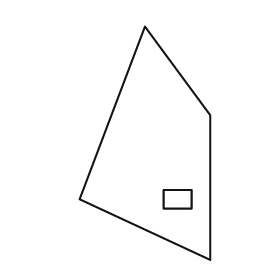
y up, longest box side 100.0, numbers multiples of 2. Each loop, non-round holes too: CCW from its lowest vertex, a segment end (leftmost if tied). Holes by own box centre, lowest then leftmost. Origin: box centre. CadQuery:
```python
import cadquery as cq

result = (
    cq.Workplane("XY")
    .moveTo(28.0, -50.0)
    .lineTo(28.0, 12.0)
    .lineTo(0.0, 50.0)
    .lineTo(-28.0, -24.0)
    .close()
    .moveTo(8.0, -28.0)
    .lineTo(20.0, -28.0)
    .lineTo(20.0, -20.0)
    .lineTo(8.0, -20.0)
    .close()
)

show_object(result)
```